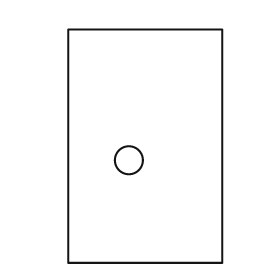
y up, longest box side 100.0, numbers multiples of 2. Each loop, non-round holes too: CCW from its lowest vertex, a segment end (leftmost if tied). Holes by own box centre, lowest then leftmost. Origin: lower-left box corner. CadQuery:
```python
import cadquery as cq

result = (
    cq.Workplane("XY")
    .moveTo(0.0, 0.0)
    .lineTo(66.0, 0.0)
    .lineTo(66.0, 100.0)
    .lineTo(0.0, 100.0)
    .close()
    .moveTo(26.0, 44.0)
    .circle(6.0)
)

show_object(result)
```